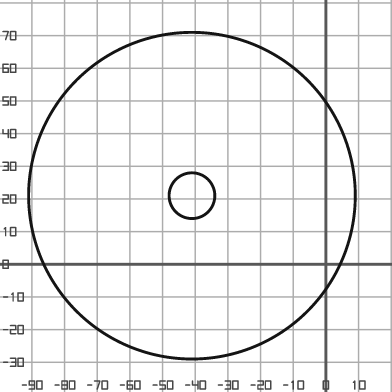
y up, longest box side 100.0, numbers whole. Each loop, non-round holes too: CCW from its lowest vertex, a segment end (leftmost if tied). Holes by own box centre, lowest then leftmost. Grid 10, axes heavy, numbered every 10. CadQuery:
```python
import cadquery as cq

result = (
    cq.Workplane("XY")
    .moveTo(-41.0, 21.0)
    .circle(50.0)
    .moveTo(-41.0, 21.0)
    .circle(7.0)
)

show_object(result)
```